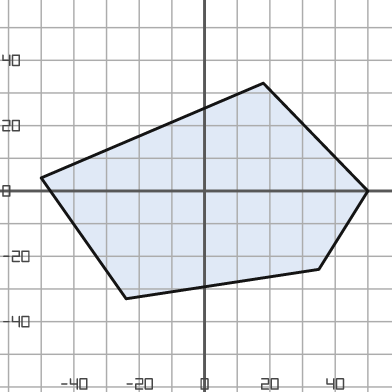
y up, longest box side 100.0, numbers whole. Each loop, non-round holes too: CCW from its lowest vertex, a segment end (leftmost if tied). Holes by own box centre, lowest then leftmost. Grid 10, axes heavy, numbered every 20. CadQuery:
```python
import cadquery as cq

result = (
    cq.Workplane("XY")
    .moveTo(-24.0, -33.0)
    .lineTo(35.0, -24.0)
    .lineTo(50.0, 0.0)
    .lineTo(18.0, 33.0)
    .lineTo(-50.0, 4.0)
    .close()
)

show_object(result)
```